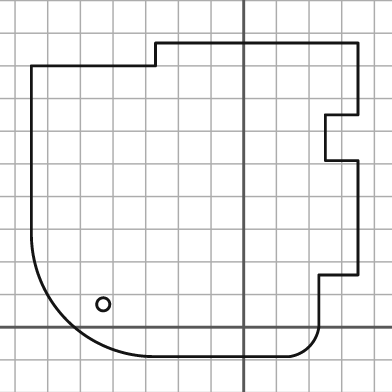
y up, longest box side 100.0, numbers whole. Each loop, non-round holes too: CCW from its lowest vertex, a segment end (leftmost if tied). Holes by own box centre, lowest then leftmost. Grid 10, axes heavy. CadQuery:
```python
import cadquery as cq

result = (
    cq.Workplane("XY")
    .moveTo(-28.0, -9.0)
    .lineTo(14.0, -9.0)
    .threePointArc((20.0, -6.0), (23.0, 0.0))
    .lineTo(23.0, 16.0)
    .lineTo(35.0, 16.0)
    .lineTo(35.0, 51.0)
    .lineTo(25.0, 51.0)
    .lineTo(25.0, 65.0)
    .lineTo(35.0, 65.0)
    .lineTo(35.0, 87.0)
    .lineTo(-27.0, 87.0)
    .lineTo(-27.0, 80.0)
    .lineTo(-65.0, 80.0)
    .lineTo(-65.0, 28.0)
    .threePointArc((-54.0, 2.0), (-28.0, -9.0))
    .close()
    .moveTo(-43.0, 7.0)
    .circle(2.0)
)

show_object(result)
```